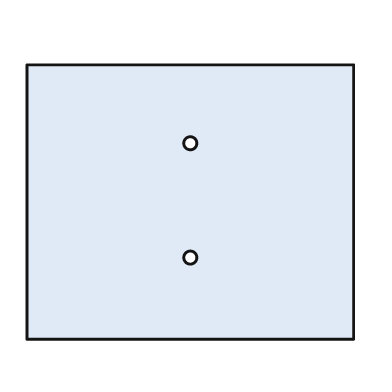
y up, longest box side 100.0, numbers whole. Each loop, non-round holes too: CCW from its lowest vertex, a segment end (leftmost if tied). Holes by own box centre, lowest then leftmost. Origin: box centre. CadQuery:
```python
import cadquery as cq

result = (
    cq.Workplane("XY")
    .moveTo(-50.0, -42.0)
    .lineTo(50.0, -42.0)
    .lineTo(50.0, 42.0)
    .lineTo(-50.0, 42.0)
    .close()
    .moveTo(0.0, -17.0)
    .circle(2.0)
    .moveTo(0.0, 18.0)
    .circle(2.0)
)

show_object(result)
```